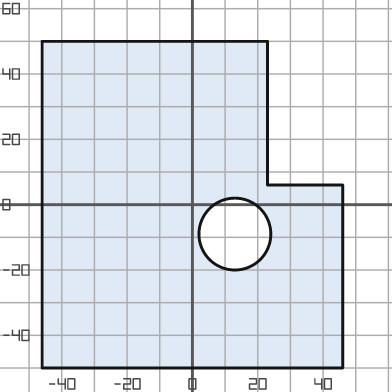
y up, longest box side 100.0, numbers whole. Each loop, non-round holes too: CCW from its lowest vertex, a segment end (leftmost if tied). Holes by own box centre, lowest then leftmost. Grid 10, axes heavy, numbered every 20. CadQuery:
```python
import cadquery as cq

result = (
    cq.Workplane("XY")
    .moveTo(-46.0, -50.0)
    .lineTo(46.0, -50.0)
    .lineTo(46.0, 6.0)
    .lineTo(23.0, 6.0)
    .lineTo(23.0, 50.0)
    .lineTo(-46.0, 50.0)
    .close()
    .moveTo(13.0, -9.0)
    .circle(11.0)
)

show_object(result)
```